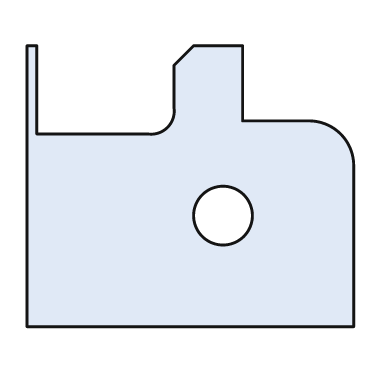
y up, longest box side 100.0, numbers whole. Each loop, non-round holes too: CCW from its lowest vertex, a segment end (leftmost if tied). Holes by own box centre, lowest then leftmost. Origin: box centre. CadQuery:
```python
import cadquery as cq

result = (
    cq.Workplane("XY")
    .moveTo(-50.0, -43.0)
    .lineTo(50.0, -43.0)
    .lineTo(50.0, 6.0)
    .threePointArc((46.0, 16.0), (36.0, 20.0))
    .lineTo(16.0, 20.0)
    .lineTo(16.0, 43.0)
    .lineTo(1.0, 43.0)
    .lineTo(-5.0, 37.0)
    .lineTo(-5.0, 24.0)
    .threePointArc((-7.0, 18.0), (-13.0, 16.0))
    .lineTo(-47.0, 16.0)
    .lineTo(-47.0, 43.0)
    .lineTo(-50.0, 43.0)
    .close()
    .moveTo(10.0, -9.0)
    .circle(9.0)
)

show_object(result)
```